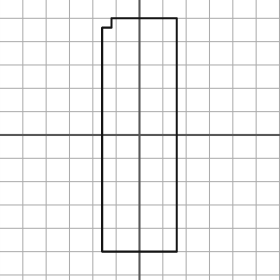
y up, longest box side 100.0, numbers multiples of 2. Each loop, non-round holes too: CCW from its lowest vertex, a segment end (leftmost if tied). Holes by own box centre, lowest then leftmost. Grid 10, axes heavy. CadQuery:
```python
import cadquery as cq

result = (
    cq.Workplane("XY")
    .moveTo(-16.0, -50.0)
    .lineTo(16.0, -50.0)
    .lineTo(16.0, 50.0)
    .lineTo(-12.0, 50.0)
    .lineTo(-12.0, 46.0)
    .lineTo(-16.0, 46.0)
    .close()
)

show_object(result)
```